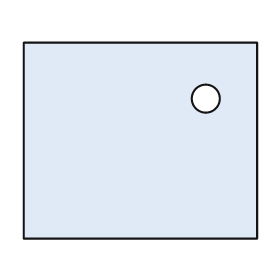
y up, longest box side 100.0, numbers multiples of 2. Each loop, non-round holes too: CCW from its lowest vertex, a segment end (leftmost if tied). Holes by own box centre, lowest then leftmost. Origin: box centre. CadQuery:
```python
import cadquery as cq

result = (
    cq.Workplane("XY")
    .moveTo(-50.0, -42.0)
    .lineTo(50.0, -42.0)
    .lineTo(50.0, 42.0)
    .lineTo(-50.0, 42.0)
    .close()
    .moveTo(28.0, 18.0)
    .circle(6.0)
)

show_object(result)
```